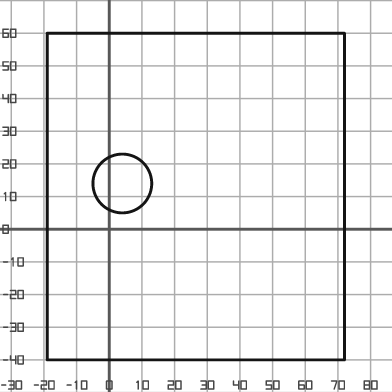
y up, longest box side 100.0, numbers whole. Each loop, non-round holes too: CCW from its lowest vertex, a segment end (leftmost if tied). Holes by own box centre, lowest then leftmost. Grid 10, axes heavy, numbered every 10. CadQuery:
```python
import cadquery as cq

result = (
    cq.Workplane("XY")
    .moveTo(-19.0, -40.0)
    .lineTo(72.0, -40.0)
    .lineTo(72.0, 60.0)
    .lineTo(-19.0, 60.0)
    .close()
    .moveTo(4.0, 14.0)
    .circle(9.0)
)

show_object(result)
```